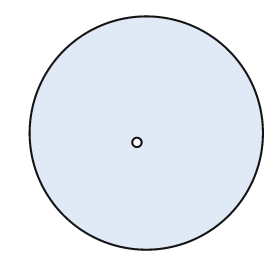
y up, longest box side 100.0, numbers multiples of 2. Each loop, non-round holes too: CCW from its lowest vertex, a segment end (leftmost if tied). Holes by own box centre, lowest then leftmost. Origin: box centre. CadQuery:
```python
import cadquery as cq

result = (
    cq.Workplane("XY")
    .moveTo(0.0, 0.0)
    .circle(50.0)
    .moveTo(-4.0, -4.0)
    .circle(2.0)
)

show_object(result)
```